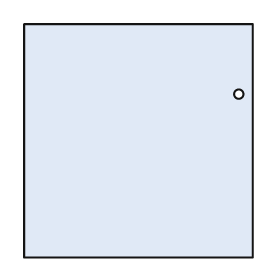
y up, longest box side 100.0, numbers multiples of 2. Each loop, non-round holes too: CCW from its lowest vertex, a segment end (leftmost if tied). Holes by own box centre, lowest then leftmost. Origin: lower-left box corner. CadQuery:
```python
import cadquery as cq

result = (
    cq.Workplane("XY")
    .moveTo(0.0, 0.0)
    .lineTo(98.0, 0.0)
    .lineTo(98.0, 100.0)
    .lineTo(0.0, 100.0)
    .close()
    .moveTo(92.0, 70.0)
    .circle(2.0)
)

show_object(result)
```